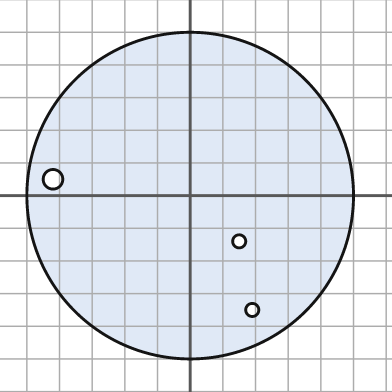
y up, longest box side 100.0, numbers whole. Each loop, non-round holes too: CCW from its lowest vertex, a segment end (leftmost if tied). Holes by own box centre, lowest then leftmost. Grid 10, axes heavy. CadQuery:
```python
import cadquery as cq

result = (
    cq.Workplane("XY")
    .moveTo(0.0, 0.0)
    .circle(50.0)
    .moveTo(19.0, -35.0)
    .circle(2.0)
    .moveTo(15.0, -14.0)
    .circle(2.0)
    .moveTo(-42.0, 5.0)
    .circle(3.0)
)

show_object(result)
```